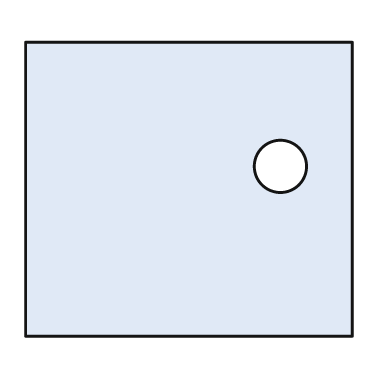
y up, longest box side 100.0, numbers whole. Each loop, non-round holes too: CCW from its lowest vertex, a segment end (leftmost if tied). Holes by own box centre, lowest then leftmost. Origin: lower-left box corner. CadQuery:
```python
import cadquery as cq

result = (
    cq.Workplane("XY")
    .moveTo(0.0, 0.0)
    .lineTo(100.0, 0.0)
    .lineTo(100.0, 90.0)
    .lineTo(0.0, 90.0)
    .close()
    .moveTo(78.0, 52.0)
    .circle(8.0)
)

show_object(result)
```